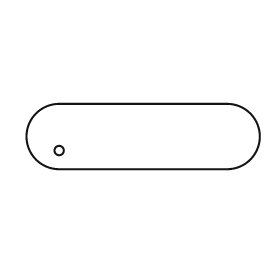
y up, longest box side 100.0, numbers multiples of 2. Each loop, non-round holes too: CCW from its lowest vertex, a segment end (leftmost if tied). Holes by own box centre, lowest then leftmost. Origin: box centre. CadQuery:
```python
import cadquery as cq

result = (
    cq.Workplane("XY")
    .moveTo(-36.0, -14.0)
    .lineTo(36.0, -14.0)
    .threePointArc((50.0, 0.0), (36.0, 14.0))
    .lineTo(-36.0, 14.0)
    .threePointArc((-50.0, 0.0), (-36.0, -14.0))
    .close()
    .moveTo(-36.0, -6.0)
    .circle(2.0)
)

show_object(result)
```